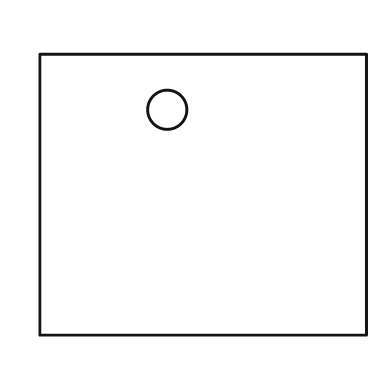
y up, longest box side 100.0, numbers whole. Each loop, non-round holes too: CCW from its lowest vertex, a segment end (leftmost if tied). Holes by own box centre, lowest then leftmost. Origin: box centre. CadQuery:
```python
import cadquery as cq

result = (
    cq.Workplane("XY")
    .moveTo(-50.0, -43.0)
    .lineTo(50.0, -43.0)
    .lineTo(50.0, 43.0)
    .lineTo(-50.0, 43.0)
    .close()
    .moveTo(-11.0, 26.0)
    .circle(6.0)
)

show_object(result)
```